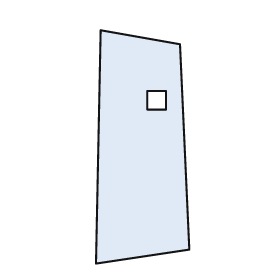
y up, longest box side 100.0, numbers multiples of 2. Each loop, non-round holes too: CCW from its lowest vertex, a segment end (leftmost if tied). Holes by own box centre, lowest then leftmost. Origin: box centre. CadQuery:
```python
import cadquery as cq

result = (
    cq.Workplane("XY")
    .moveTo(-20.0, -50.0)
    .lineTo(20.0, -44.0)
    .lineTo(16.0, 44.0)
    .lineTo(-18.0, 50.0)
    .close()
    .moveTo(2.0, 16.0)
    .lineTo(10.0, 16.0)
    .lineTo(10.0, 24.0)
    .lineTo(2.0, 24.0)
    .close()
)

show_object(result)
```